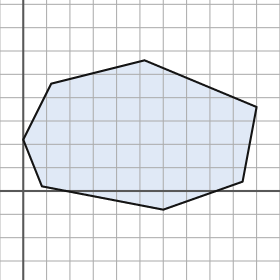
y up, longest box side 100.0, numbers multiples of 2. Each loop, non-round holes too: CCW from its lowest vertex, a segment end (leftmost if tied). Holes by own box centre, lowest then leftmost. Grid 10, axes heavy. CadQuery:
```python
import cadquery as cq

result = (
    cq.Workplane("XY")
    .moveTo(60.0, -8.0)
    .lineTo(94.0, 4.0)
    .lineTo(100.0, 36.0)
    .lineTo(52.0, 56.0)
    .lineTo(12.0, 46.0)
    .lineTo(0.0, 22.0)
    .lineTo(8.0, 2.0)
    .close()
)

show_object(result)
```